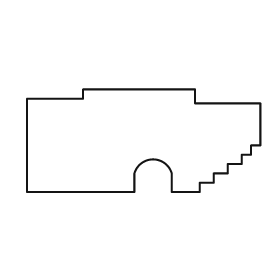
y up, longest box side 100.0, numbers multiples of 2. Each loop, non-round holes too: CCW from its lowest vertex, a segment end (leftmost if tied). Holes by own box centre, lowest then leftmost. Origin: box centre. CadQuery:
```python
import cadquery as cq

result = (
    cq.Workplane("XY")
    .moveTo(-50.0, -22.0)
    .lineTo(-4.0, -22.0)
    .lineTo(-4.0, -14.0)
    .threePointArc((4.0, -8.0), (12.0, -14.0))
    .lineTo(12.0, -22.0)
    .lineTo(24.0, -22.0)
    .lineTo(24.0, -18.0)
    .lineTo(30.0, -18.0)
    .lineTo(30.0, -14.0)
    .lineTo(36.0, -14.0)
    .lineTo(36.0, -10.0)
    .lineTo(42.0, -10.0)
    .lineTo(42.0, -6.0)
    .lineTo(46.0, -6.0)
    .lineTo(46.0, -2.0)
    .lineTo(50.0, -2.0)
    .lineTo(50.0, 16.0)
    .lineTo(22.0, 16.0)
    .lineTo(22.0, 22.0)
    .lineTo(-26.0, 22.0)
    .lineTo(-26.0, 18.0)
    .lineTo(-50.0, 18.0)
    .close()
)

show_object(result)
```